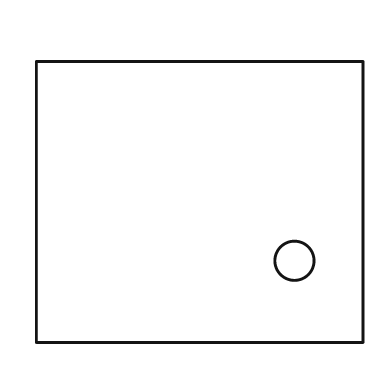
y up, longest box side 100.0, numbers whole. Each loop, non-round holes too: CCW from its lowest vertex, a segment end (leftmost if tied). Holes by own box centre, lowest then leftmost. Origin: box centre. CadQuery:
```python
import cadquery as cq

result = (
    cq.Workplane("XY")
    .moveTo(-50.0, -43.0)
    .lineTo(50.0, -43.0)
    .lineTo(50.0, 43.0)
    .lineTo(-50.0, 43.0)
    .close()
    .moveTo(29.0, -18.0)
    .circle(6.0)
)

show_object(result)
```